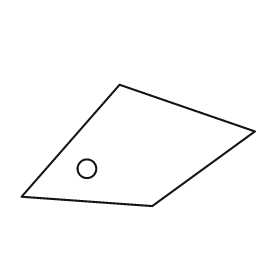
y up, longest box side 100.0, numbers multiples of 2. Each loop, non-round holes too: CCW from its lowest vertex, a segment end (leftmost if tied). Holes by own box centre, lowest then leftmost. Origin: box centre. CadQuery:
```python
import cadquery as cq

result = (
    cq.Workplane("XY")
    .moveTo(6.0, -26.0)
    .lineTo(50.0, 6.0)
    .lineTo(-8.0, 26.0)
    .lineTo(-50.0, -22.0)
    .close()
    .moveTo(-22.0, -10.0)
    .circle(4.0)
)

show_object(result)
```